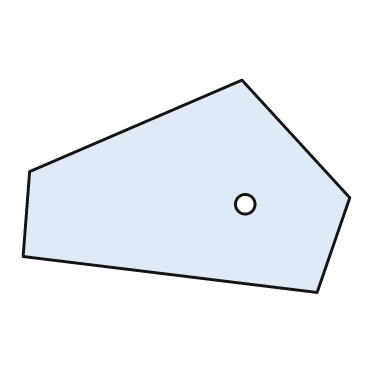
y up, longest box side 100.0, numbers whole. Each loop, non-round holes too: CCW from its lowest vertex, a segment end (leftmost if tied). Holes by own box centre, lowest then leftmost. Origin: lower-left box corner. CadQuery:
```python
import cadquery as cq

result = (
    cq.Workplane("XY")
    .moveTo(90.0, 0.0)
    .lineTo(100.0, 29.0)
    .lineTo(67.0, 65.0)
    .lineTo(2.0, 37.0)
    .lineTo(0.0, 11.0)
    .close()
    .moveTo(68.0, 27.0)
    .circle(3.0)
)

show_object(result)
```